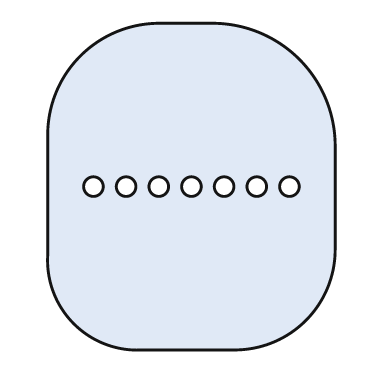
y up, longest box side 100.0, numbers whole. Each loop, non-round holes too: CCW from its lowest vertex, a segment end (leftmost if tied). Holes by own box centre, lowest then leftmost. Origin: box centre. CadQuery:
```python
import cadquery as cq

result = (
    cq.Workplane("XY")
    .moveTo(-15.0, -50.0)
    .lineTo(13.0, -50.0)
    .threePointArc((35.0, -41.0), (44.0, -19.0))
    .lineTo(44.0, 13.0)
    .threePointArc((33.0, 39.0), (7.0, 50.0))
    .lineTo(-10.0, 50.0)
    .threePointArc((-34.0, 40.0), (-44.0, 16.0))
    .lineTo(-44.0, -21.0)
    .threePointArc((-36.0, -42.0), (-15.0, -50.0))
    .close()
    .moveTo(-30.0, 0.0)
    .circle(3.0)
    .moveTo(-20.0, 0.0)
    .circle(3.0)
    .moveTo(-10.0, 0.0)
    .circle(3.0)
    .moveTo(0.0, 0.0)
    .circle(3.0)
    .moveTo(10.0, 0.0)
    .circle(3.0)
    .moveTo(20.0, 0.0)
    .circle(3.0)
    .moveTo(30.0, 0.0)
    .circle(3.0)
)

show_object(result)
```